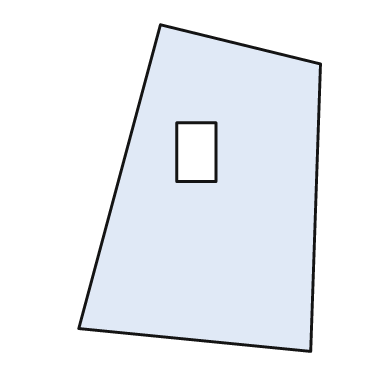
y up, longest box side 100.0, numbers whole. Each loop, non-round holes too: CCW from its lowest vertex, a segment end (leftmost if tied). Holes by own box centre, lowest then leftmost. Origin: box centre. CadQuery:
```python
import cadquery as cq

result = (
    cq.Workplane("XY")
    .moveTo(34.0, -50.0)
    .lineTo(37.0, 38.0)
    .lineTo(-12.0, 50.0)
    .lineTo(-37.0, -43.0)
    .close()
    .moveTo(-7.0, 2.0)
    .lineTo(5.0, 2.0)
    .lineTo(5.0, 20.0)
    .lineTo(-7.0, 20.0)
    .close()
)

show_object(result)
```